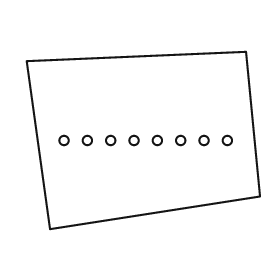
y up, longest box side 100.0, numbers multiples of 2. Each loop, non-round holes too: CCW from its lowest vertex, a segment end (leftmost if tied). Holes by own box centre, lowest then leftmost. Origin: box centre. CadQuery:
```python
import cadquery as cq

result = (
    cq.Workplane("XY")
    .moveTo(-40.0, -38.0)
    .lineTo(50.0, -24.0)
    .lineTo(44.0, 38.0)
    .lineTo(-50.0, 34.0)
    .close()
    .moveTo(-34.0, 0.0)
    .circle(2.0)
    .moveTo(-24.0, 0.0)
    .circle(2.0)
    .moveTo(-14.0, 0.0)
    .circle(2.0)
    .moveTo(-4.0, 0.0)
    .circle(2.0)
    .moveTo(6.0, 0.0)
    .circle(2.0)
    .moveTo(16.0, 0.0)
    .circle(2.0)
    .moveTo(26.0, 0.0)
    .circle(2.0)
    .moveTo(36.0, 0.0)
    .circle(2.0)
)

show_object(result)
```